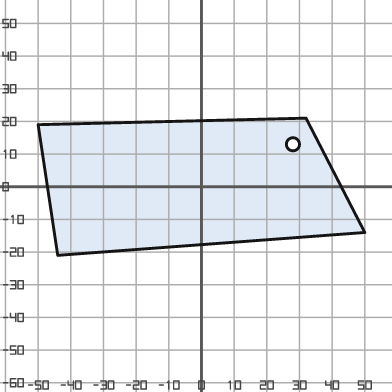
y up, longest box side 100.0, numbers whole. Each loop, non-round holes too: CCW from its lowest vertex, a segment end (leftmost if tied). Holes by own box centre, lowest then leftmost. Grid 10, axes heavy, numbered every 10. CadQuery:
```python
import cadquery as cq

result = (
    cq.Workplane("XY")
    .moveTo(-44.0, -21.0)
    .lineTo(50.0, -14.0)
    .lineTo(32.0, 21.0)
    .lineTo(-50.0, 19.0)
    .close()
    .moveTo(28.0, 13.0)
    .circle(2.0)
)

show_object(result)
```